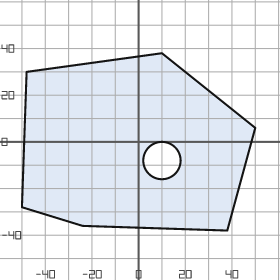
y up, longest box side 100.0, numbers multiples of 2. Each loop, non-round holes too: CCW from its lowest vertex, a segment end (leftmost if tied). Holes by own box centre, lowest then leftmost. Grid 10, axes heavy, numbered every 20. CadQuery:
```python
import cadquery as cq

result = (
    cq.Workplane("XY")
    .moveTo(38.0, -38.0)
    .lineTo(50.0, 6.0)
    .lineTo(10.0, 38.0)
    .lineTo(-48.0, 30.0)
    .lineTo(-50.0, -28.0)
    .lineTo(-24.0, -36.0)
    .close()
    .moveTo(10.0, -8.0)
    .circle(8.0)
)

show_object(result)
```